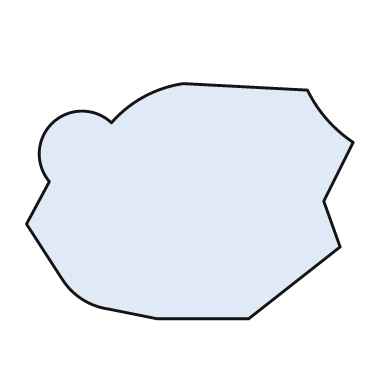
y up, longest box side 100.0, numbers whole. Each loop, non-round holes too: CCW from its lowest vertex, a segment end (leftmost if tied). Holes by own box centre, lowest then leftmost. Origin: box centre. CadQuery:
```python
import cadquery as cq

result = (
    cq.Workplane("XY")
    .moveTo(-10.0, -36.0)
    .lineTo(18.0, -36.0)
    .lineTo(46.0, -14.0)
    .lineTo(41.0, 0.0)
    .lineTo(50.0, 18.0)
    .threePointArc((42.0, 25.0), (36.0, 34.0))
    .lineTo(-2.0, 36.0)
    .threePointArc((-14.0, 32.0), (-24.0, 24.0))
    .threePointArc((-42.0, 24.0), (-43.0, 6.0))
    .lineTo(-50.0, -7.0)
    .lineTo(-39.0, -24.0)
    .threePointArc((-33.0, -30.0), (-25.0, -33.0))
    .close()
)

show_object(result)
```